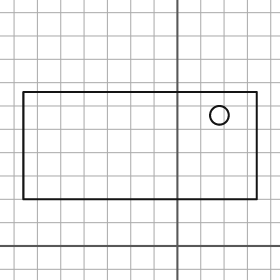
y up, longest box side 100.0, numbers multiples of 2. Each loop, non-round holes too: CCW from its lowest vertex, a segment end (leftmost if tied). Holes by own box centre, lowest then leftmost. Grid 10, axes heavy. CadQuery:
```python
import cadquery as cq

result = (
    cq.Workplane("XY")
    .moveTo(-66.0, 20.0)
    .lineTo(34.0, 20.0)
    .lineTo(34.0, 66.0)
    .lineTo(-66.0, 66.0)
    .close()
    .moveTo(18.0, 56.0)
    .circle(4.0)
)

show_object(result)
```